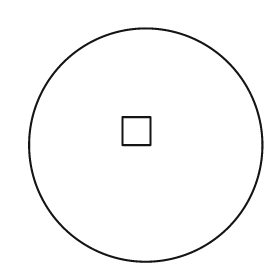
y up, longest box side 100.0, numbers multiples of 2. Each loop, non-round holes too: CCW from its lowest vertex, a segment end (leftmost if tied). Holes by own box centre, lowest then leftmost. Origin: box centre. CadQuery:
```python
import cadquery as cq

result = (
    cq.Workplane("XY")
    .moveTo(0.0, 0.0)
    .circle(50.0)
    .moveTo(-10.0, 0.0)
    .lineTo(2.0, 0.0)
    .lineTo(2.0, 12.0)
    .lineTo(-10.0, 12.0)
    .close()
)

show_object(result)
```